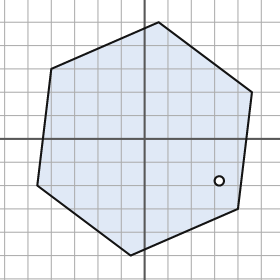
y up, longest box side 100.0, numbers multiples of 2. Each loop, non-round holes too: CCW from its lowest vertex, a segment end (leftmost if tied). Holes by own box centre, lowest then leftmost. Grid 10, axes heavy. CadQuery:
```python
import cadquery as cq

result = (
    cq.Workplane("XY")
    .moveTo(-6.0, -50.0)
    .lineTo(40.0, -30.0)
    .lineTo(46.0, 20.0)
    .lineTo(6.0, 50.0)
    .lineTo(-40.0, 30.0)
    .lineTo(-46.0, -20.0)
    .close()
    .moveTo(32.0, -18.0)
    .circle(2.0)
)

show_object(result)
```